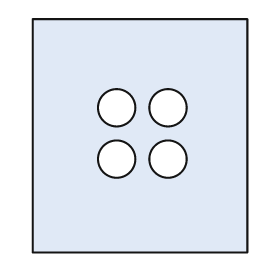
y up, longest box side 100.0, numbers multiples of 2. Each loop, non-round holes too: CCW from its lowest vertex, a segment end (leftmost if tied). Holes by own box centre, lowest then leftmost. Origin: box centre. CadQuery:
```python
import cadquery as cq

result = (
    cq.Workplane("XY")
    .moveTo(-46.0, -50.0)
    .lineTo(46.0, -50.0)
    .lineTo(46.0, 50.0)
    .lineTo(-46.0, 50.0)
    .close()
    .moveTo(-10.0, -10.0)
    .circle(8.0)
    .moveTo(12.0, -10.0)
    .circle(8.0)
    .moveTo(-10.0, 12.0)
    .circle(8.0)
    .moveTo(12.0, 12.0)
    .circle(8.0)
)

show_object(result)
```